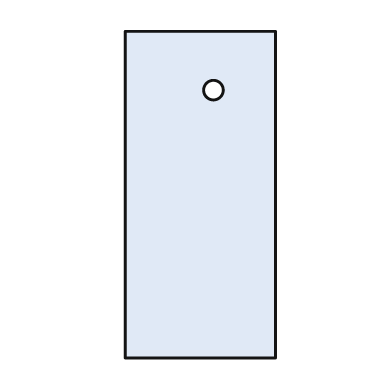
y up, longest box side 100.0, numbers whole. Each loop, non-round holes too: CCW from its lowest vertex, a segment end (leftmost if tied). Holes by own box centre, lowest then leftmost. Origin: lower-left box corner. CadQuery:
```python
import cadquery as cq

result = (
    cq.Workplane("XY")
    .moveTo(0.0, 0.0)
    .lineTo(46.0, 0.0)
    .lineTo(46.0, 100.0)
    .lineTo(0.0, 100.0)
    .close()
    .moveTo(27.0, 82.0)
    .circle(3.0)
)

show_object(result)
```